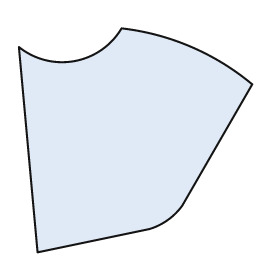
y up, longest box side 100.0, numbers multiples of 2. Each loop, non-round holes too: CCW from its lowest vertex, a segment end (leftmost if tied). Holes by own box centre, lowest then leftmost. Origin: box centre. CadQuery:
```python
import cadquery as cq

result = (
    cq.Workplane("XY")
    .moveTo(-42.0, -48.0)
    .lineTo(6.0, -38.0)
    .threePointArc((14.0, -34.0), (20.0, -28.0))
    .lineTo(50.0, 24.0)
    .threePointArc((24.0, 40.0), (-6.0, 48.0))
    .threePointArc((-26.0, 34.0), (-50.0, 40.0))
    .close()
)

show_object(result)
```